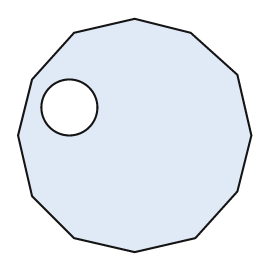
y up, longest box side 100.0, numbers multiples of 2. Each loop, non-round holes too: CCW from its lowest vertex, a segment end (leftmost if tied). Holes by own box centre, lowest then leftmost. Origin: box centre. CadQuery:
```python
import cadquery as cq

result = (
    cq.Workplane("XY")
    .moveTo(0.0, -50.0)
    .lineTo(26.0, -44.0)
    .lineTo(44.0, -24.0)
    .lineTo(50.0, 0.0)
    .lineTo(44.0, 26.0)
    .lineTo(24.0, 44.0)
    .lineTo(0.0, 50.0)
    .lineTo(-26.0, 44.0)
    .lineTo(-44.0, 24.0)
    .lineTo(-50.0, 0.0)
    .lineTo(-44.0, -26.0)
    .lineTo(-26.0, -44.0)
    .close()
    .moveTo(-28.0, 12.0)
    .circle(12.0)
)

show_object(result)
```